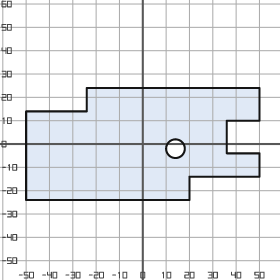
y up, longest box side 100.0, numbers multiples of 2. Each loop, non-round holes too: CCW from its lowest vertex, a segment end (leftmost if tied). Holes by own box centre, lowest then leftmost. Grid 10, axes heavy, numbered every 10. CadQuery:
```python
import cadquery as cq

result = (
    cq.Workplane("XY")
    .moveTo(-50.0, -24.0)
    .lineTo(20.0, -24.0)
    .lineTo(20.0, -14.0)
    .lineTo(50.0, -14.0)
    .lineTo(50.0, -4.0)
    .lineTo(36.0, -4.0)
    .lineTo(36.0, 10.0)
    .lineTo(50.0, 10.0)
    .lineTo(50.0, 24.0)
    .lineTo(-24.0, 24.0)
    .lineTo(-24.0, 14.0)
    .lineTo(-50.0, 14.0)
    .close()
    .moveTo(14.0, -2.0)
    .circle(4.0)
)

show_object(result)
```